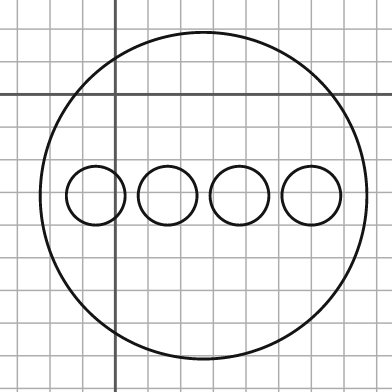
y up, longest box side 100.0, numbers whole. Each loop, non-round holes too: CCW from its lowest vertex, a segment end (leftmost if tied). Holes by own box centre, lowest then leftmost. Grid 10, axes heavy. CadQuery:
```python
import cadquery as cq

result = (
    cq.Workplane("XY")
    .moveTo(27.0, -31.0)
    .circle(50.0)
    .moveTo(-6.0, -31.0)
    .circle(9.0)
    .moveTo(16.0, -31.0)
    .circle(9.0)
    .moveTo(38.0, -31.0)
    .circle(9.0)
    .moveTo(60.0, -31.0)
    .circle(9.0)
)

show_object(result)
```